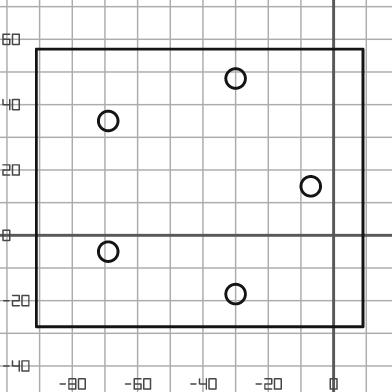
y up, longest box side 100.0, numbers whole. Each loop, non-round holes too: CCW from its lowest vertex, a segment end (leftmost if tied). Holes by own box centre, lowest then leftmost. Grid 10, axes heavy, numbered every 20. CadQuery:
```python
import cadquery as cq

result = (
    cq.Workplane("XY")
    .moveTo(-91.0, -28.0)
    .lineTo(9.0, -28.0)
    .lineTo(9.0, 57.0)
    .lineTo(-91.0, 57.0)
    .close()
    .moveTo(-30.0, -18.0)
    .circle(3.0)
    .moveTo(-69.0, -5.0)
    .circle(3.0)
    .moveTo(-7.0, 15.0)
    .circle(3.0)
    .moveTo(-69.0, 35.0)
    .circle(3.0)
    .moveTo(-30.0, 48.0)
    .circle(3.0)
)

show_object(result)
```